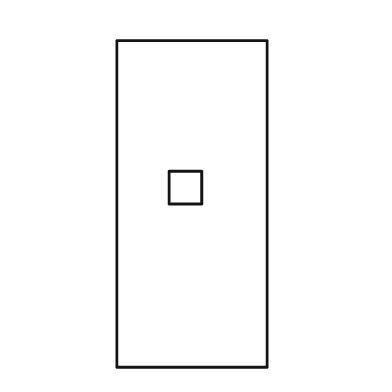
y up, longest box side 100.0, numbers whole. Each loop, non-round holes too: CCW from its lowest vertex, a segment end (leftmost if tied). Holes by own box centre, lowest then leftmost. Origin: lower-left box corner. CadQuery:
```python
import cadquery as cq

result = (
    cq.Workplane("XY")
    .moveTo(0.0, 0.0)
    .lineTo(46.0, 0.0)
    .lineTo(46.0, 100.0)
    .lineTo(0.0, 100.0)
    .close()
    .moveTo(16.0, 50.0)
    .lineTo(26.0, 50.0)
    .lineTo(26.0, 60.0)
    .lineTo(16.0, 60.0)
    .close()
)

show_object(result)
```